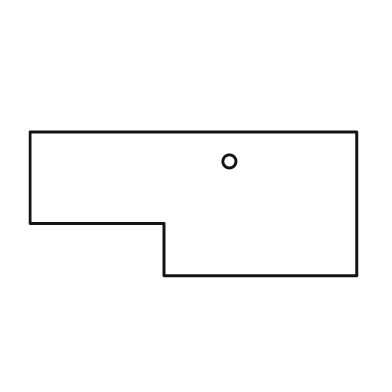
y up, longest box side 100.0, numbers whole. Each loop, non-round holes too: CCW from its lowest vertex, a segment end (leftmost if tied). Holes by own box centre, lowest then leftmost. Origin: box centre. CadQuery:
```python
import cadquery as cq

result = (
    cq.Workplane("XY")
    .moveTo(-9.0, -22.0)
    .lineTo(50.0, -22.0)
    .lineTo(50.0, 22.0)
    .lineTo(-50.0, 22.0)
    .lineTo(-50.0, -6.0)
    .lineTo(-9.0, -6.0)
    .close()
    .moveTo(11.0, 13.0)
    .circle(2.0)
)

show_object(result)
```